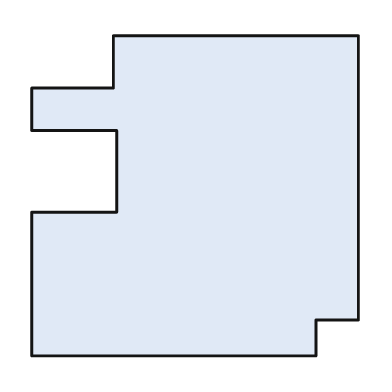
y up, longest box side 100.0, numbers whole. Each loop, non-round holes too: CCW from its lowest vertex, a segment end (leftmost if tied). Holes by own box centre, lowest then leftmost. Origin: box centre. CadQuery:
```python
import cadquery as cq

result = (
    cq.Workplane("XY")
    .moveTo(-50.0, -49.0)
    .lineTo(37.0, -49.0)
    .lineTo(37.0, -38.0)
    .lineTo(50.0, -38.0)
    .lineTo(50.0, 49.0)
    .lineTo(-25.0, 49.0)
    .lineTo(-25.0, 33.0)
    .lineTo(-50.0, 33.0)
    .lineTo(-50.0, 20.0)
    .lineTo(-24.0, 20.0)
    .lineTo(-24.0, -5.0)
    .lineTo(-50.0, -5.0)
    .close()
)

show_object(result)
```